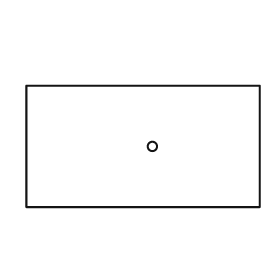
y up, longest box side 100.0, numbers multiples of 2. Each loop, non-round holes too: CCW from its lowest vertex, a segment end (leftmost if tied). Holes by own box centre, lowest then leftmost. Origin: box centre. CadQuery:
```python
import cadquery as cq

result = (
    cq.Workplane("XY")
    .moveTo(-50.0, -26.0)
    .lineTo(50.0, -26.0)
    .lineTo(50.0, 26.0)
    .lineTo(-50.0, 26.0)
    .close()
    .moveTo(4.0, 0.0)
    .circle(2.0)
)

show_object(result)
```